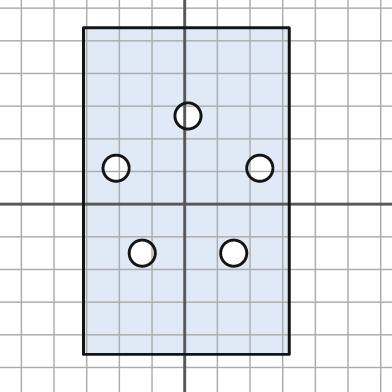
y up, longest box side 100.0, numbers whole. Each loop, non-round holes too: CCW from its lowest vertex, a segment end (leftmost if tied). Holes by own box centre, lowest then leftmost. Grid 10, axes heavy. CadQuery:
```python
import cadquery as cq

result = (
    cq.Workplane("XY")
    .moveTo(-31.0, -46.0)
    .lineTo(32.0, -46.0)
    .lineTo(32.0, 54.0)
    .lineTo(-31.0, 54.0)
    .close()
    .moveTo(-13.0, -15.0)
    .circle(4.0)
    .moveTo(15.0, -15.0)
    .circle(4.0)
    .moveTo(-21.0, 11.0)
    .circle(4.0)
    .moveTo(23.0, 11.0)
    .circle(4.0)
    .moveTo(1.0, 27.0)
    .circle(4.0)
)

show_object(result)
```